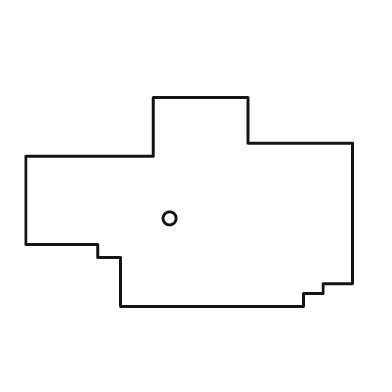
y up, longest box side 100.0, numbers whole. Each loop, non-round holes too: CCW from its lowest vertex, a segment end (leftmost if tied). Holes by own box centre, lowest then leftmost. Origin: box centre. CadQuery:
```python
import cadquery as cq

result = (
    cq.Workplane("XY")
    .moveTo(-21.0, -32.0)
    .lineTo(35.0, -32.0)
    .lineTo(35.0, -28.0)
    .lineTo(41.0, -28.0)
    .lineTo(41.0, -25.0)
    .lineTo(50.0, -25.0)
    .lineTo(50.0, 18.0)
    .lineTo(18.0, 18.0)
    .lineTo(18.0, 32.0)
    .lineTo(-11.0, 32.0)
    .lineTo(-11.0, 14.0)
    .lineTo(-50.0, 14.0)
    .lineTo(-50.0, -13.0)
    .lineTo(-28.0, -13.0)
    .lineTo(-28.0, -17.0)
    .lineTo(-21.0, -17.0)
    .close()
    .moveTo(-6.0, -5.0)
    .circle(2.0)
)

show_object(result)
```